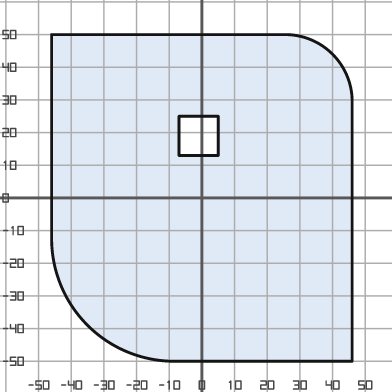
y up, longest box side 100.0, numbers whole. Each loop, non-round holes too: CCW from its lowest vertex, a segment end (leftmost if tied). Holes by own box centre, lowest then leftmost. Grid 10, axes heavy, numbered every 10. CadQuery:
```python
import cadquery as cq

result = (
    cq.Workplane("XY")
    .moveTo(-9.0, -50.0)
    .lineTo(46.0, -50.0)
    .lineTo(46.0, 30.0)
    .threePointArc((40.0, 44.0), (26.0, 50.0))
    .lineTo(-46.0, 50.0)
    .lineTo(-46.0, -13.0)
    .threePointArc((-35.0, -39.0), (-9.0, -50.0))
    .close()
    .moveTo(-7.0, 13.0)
    .lineTo(5.0, 13.0)
    .lineTo(5.0, 25.0)
    .lineTo(-7.0, 25.0)
    .close()
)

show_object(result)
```